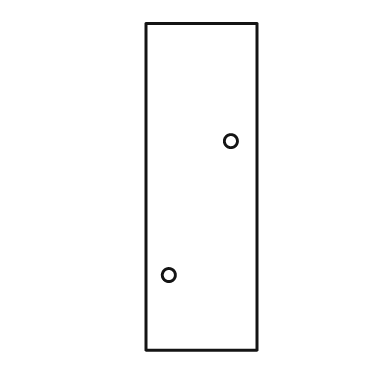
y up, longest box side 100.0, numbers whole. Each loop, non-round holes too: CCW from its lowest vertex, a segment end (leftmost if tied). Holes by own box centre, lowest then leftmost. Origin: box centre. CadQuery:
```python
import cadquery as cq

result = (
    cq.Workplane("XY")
    .moveTo(-17.0, -50.0)
    .lineTo(17.0, -50.0)
    .lineTo(17.0, 50.0)
    .lineTo(-17.0, 50.0)
    .close()
    .moveTo(-10.0, -27.0)
    .circle(2.0)
    .moveTo(9.0, 14.0)
    .circle(2.0)
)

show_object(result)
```